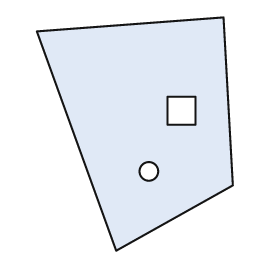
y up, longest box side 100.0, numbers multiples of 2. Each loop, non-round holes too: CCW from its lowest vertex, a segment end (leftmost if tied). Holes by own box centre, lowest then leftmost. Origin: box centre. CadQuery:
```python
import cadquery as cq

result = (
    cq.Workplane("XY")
    .moveTo(-8.0, -50.0)
    .lineTo(42.0, -22.0)
    .lineTo(38.0, 50.0)
    .lineTo(-42.0, 44.0)
    .close()
    .moveTo(6.0, -16.0)
    .circle(4.0)
    .moveTo(14.0, 4.0)
    .lineTo(26.0, 4.0)
    .lineTo(26.0, 16.0)
    .lineTo(14.0, 16.0)
    .close()
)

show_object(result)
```